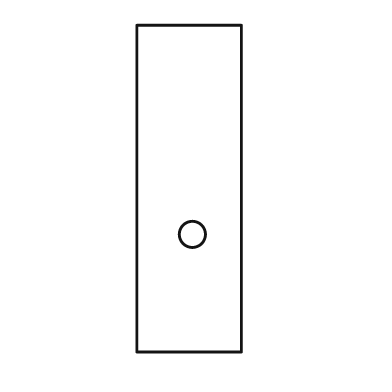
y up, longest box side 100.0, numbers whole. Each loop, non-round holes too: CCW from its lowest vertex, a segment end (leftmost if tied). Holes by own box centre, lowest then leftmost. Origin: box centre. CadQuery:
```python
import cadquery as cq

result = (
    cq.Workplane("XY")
    .moveTo(-16.0, -50.0)
    .lineTo(16.0, -50.0)
    .lineTo(16.0, 50.0)
    .lineTo(-16.0, 50.0)
    .close()
    .moveTo(1.0, -14.0)
    .circle(4.0)
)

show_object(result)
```